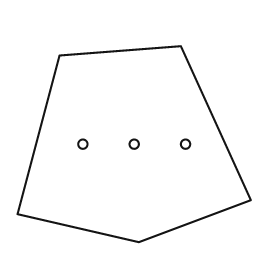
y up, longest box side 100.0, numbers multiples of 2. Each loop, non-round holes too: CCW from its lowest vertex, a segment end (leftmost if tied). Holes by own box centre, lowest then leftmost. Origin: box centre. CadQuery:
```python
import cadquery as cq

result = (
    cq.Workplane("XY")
    .moveTo(2.0, -42.0)
    .lineTo(50.0, -24.0)
    .lineTo(20.0, 42.0)
    .lineTo(-32.0, 38.0)
    .lineTo(-50.0, -30.0)
    .close()
    .moveTo(-22.0, 0.0)
    .circle(2.0)
    .moveTo(0.0, 0.0)
    .circle(2.0)
    .moveTo(22.0, 0.0)
    .circle(2.0)
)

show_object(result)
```